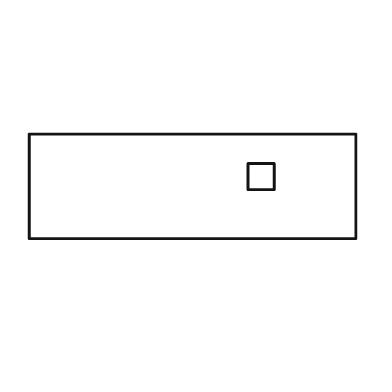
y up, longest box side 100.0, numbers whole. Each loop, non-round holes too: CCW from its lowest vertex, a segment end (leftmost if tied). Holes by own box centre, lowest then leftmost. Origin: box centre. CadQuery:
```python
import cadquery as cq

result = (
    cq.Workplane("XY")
    .moveTo(-50.0, -16.0)
    .lineTo(50.0, -16.0)
    .lineTo(50.0, 16.0)
    .lineTo(-50.0, 16.0)
    .close()
    .moveTo(17.0, -1.0)
    .lineTo(25.0, -1.0)
    .lineTo(25.0, 7.0)
    .lineTo(17.0, 7.0)
    .close()
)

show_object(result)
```